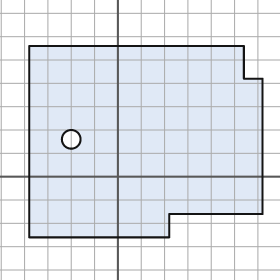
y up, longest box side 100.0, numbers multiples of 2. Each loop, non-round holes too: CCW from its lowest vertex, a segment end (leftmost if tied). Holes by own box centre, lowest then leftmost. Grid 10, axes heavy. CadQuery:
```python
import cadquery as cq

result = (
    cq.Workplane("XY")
    .moveTo(-38.0, -26.0)
    .lineTo(22.0, -26.0)
    .lineTo(22.0, -16.0)
    .lineTo(62.0, -16.0)
    .lineTo(62.0, 42.0)
    .lineTo(54.0, 42.0)
    .lineTo(54.0, 56.0)
    .lineTo(-38.0, 56.0)
    .close()
    .moveTo(-20.0, 16.0)
    .circle(4.0)
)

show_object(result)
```